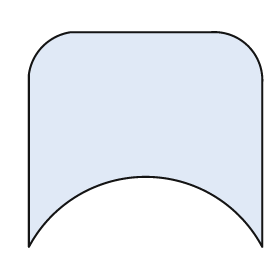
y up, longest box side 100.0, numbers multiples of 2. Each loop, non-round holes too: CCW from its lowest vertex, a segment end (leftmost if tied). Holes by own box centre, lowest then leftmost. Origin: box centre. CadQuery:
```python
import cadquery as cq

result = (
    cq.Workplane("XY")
    .moveTo(-50.0, -46.0)
    .threePointArc((0.0, -16.0), (50.0, -46.0))
    .lineTo(50.0, 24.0)
    .threePointArc((44.0, 40.0), (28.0, 46.0))
    .lineTo(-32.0, 46.0)
    .threePointArc((-44.0, 40.0), (-50.0, 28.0))
    .close()
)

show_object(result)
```